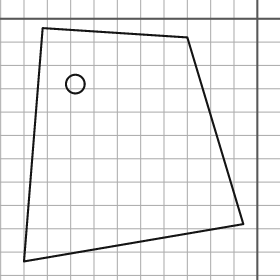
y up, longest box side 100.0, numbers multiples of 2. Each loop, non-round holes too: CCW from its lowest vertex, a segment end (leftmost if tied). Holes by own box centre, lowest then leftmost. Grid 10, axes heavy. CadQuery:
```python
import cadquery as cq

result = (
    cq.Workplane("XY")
    .moveTo(-100.0, -104.0)
    .lineTo(-6.0, -88.0)
    .lineTo(-30.0, -8.0)
    .lineTo(-92.0, -4.0)
    .close()
    .moveTo(-78.0, -28.0)
    .circle(4.0)
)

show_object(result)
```